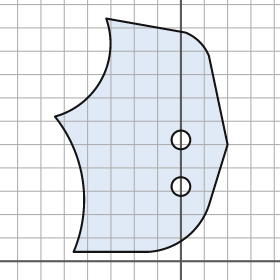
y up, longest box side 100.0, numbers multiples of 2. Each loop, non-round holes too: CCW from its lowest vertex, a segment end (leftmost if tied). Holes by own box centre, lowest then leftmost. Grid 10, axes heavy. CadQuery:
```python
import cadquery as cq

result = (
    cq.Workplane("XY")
    .moveTo(-46.0, 4.0)
    .lineTo(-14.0, 4.0)
    .threePointArc((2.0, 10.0), (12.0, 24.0))
    .lineTo(20.0, 50.0)
    .lineTo(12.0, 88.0)
    .threePointArc((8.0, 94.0), (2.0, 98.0))
    .lineTo(-32.0, 104.0)
    .threePointArc((-34.0, 78.0), (-54.0, 62.0))
    .threePointArc((-42.0, 34.0), (-46.0, 4.0))
    .close()
    .moveTo(0.0, 32.0)
    .circle(4.0)
    .moveTo(0.0, 52.0)
    .circle(4.0)
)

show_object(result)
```